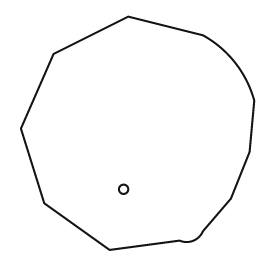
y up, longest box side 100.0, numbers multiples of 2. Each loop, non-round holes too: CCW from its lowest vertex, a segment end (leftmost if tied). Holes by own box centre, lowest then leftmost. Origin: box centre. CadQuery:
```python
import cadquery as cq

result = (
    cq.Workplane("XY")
    .moveTo(-12.0, -50.0)
    .lineTo(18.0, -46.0)
    .threePointArc((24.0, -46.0), (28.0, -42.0))
    .lineTo(40.0, -28.0)
    .lineTo(48.0, -8.0)
    .lineTo(50.0, 14.0)
    .threePointArc((42.0, 30.0), (28.0, 42.0))
    .lineTo(-4.0, 50.0)
    .lineTo(-36.0, 34.0)
    .lineTo(-50.0, 2.0)
    .lineTo(-40.0, -30.0)
    .close()
    .moveTo(-6.0, -24.0)
    .circle(2.0)
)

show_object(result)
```